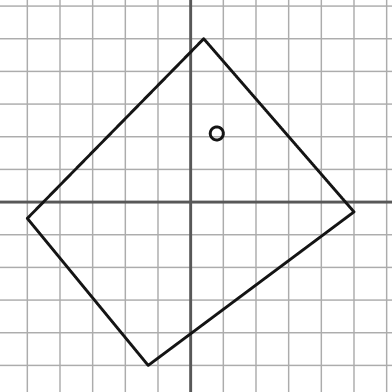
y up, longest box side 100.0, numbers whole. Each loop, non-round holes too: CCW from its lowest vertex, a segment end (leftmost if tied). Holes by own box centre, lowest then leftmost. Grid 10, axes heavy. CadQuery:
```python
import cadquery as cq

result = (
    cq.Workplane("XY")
    .moveTo(-13.0, -50.0)
    .lineTo(50.0, -3.0)
    .lineTo(4.0, 50.0)
    .lineTo(-50.0, -5.0)
    .close()
    .moveTo(8.0, 21.0)
    .circle(2.0)
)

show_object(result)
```